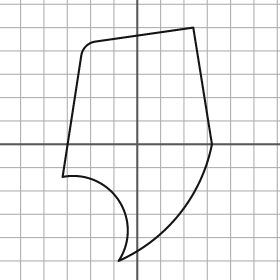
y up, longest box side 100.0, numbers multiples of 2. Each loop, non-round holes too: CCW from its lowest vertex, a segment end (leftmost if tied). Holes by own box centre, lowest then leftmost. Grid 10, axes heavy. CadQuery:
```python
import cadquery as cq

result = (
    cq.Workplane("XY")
    .moveTo(-8.0, -50.0)
    .threePointArc((18.0, -30.0), (32.0, 0.0))
    .lineTo(24.0, 50.0)
    .lineTo(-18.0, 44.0)
    .threePointArc((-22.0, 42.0), (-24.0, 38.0))
    .lineTo(-32.0, -14.0)
    .threePointArc((-8.0, -24.0), (-8.0, -50.0))
    .close()
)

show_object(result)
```